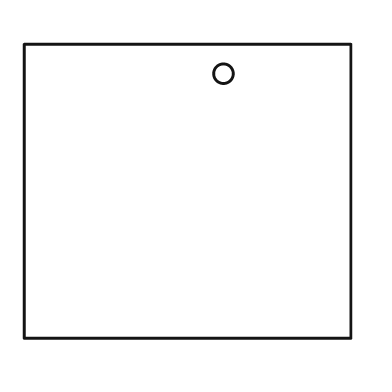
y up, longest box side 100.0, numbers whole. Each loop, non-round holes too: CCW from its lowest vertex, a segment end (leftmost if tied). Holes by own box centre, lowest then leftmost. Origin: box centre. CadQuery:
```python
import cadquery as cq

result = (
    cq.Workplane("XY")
    .moveTo(-50.0, -45.0)
    .lineTo(50.0, -45.0)
    .lineTo(50.0, 45.0)
    .lineTo(-50.0, 45.0)
    .close()
    .moveTo(11.0, 36.0)
    .circle(3.0)
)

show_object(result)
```